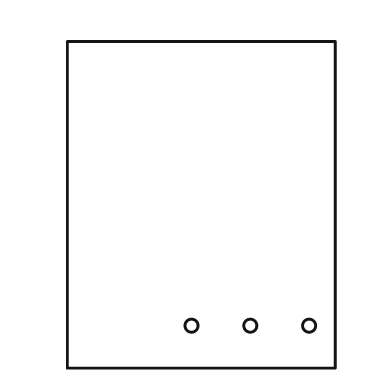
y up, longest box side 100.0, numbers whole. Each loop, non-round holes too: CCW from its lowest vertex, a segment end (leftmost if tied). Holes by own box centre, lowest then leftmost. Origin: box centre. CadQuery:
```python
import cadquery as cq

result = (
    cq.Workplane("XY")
    .moveTo(-41.0, -50.0)
    .lineTo(41.0, -50.0)
    .lineTo(41.0, 50.0)
    .lineTo(-41.0, 50.0)
    .close()
    .moveTo(-3.0, -37.0)
    .circle(2.0)
    .moveTo(15.0, -37.0)
    .circle(2.0)
    .moveTo(33.0, -37.0)
    .circle(2.0)
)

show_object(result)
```